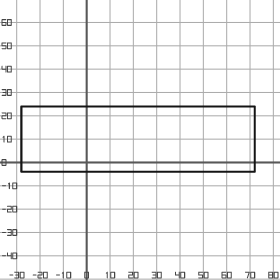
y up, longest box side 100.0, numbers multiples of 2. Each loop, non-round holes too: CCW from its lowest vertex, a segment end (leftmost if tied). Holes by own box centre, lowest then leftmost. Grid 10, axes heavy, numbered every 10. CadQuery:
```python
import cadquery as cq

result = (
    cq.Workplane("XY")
    .moveTo(-28.0, -4.0)
    .lineTo(72.0, -4.0)
    .lineTo(72.0, 24.0)
    .lineTo(-28.0, 24.0)
    .close()
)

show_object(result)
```